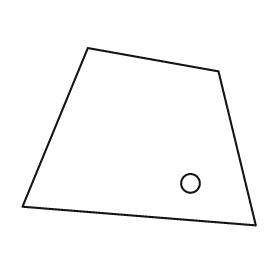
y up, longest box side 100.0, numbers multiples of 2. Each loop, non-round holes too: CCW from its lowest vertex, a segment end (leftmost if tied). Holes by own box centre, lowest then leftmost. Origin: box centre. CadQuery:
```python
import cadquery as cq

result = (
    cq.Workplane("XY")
    .moveTo(50.0, -38.0)
    .lineTo(34.0, 28.0)
    .lineTo(-22.0, 38.0)
    .lineTo(-50.0, -30.0)
    .close()
    .moveTo(22.0, -20.0)
    .circle(4.0)
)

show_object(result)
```